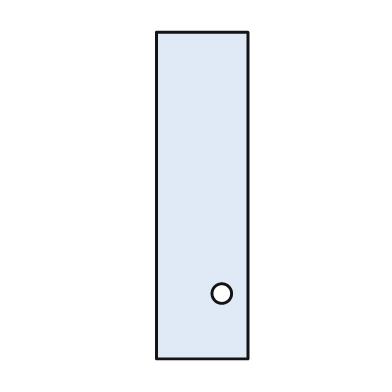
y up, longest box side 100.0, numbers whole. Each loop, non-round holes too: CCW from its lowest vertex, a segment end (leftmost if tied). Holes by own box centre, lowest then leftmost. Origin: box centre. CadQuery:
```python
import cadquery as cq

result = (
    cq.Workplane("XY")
    .moveTo(-14.0, -50.0)
    .lineTo(14.0, -50.0)
    .lineTo(14.0, 50.0)
    .lineTo(-14.0, 50.0)
    .close()
    .moveTo(6.0, -30.0)
    .circle(3.0)
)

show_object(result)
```